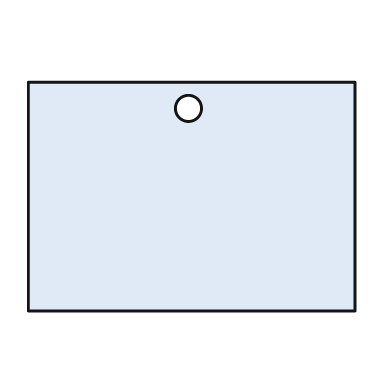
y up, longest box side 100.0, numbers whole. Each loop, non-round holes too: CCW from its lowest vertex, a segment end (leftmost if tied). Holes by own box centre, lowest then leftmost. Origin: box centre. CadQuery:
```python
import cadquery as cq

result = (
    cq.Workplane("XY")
    .moveTo(-50.0, -35.0)
    .lineTo(50.0, -35.0)
    .lineTo(50.0, 35.0)
    .lineTo(-50.0, 35.0)
    .close()
    .moveTo(-1.0, 27.0)
    .circle(4.0)
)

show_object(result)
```